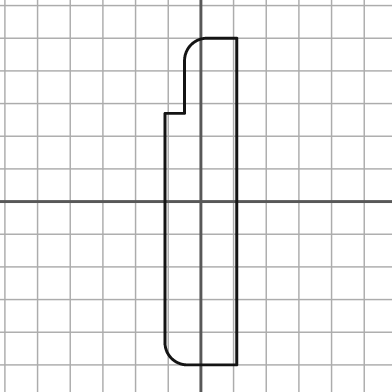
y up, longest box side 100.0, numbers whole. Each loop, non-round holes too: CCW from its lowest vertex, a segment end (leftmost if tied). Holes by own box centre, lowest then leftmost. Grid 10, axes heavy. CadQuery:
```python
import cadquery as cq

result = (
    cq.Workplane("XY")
    .moveTo(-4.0, -50.0)
    .lineTo(11.0, -50.0)
    .lineTo(11.0, 50.0)
    .lineTo(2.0, 50.0)
    .threePointArc((-3.0, 48.0), (-5.0, 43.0))
    .lineTo(-5.0, 27.0)
    .lineTo(-11.0, 27.0)
    .lineTo(-11.0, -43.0)
    .threePointArc((-9.0, -48.0), (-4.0, -50.0))
    .close()
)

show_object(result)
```